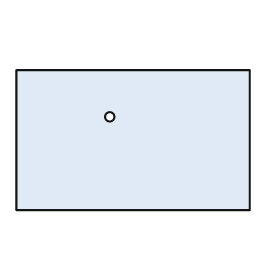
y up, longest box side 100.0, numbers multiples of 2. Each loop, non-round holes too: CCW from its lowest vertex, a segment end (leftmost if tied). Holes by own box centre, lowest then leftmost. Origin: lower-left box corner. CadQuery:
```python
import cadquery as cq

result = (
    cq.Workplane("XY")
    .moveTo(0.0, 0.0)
    .lineTo(100.0, 0.0)
    .lineTo(100.0, 60.0)
    .lineTo(0.0, 60.0)
    .close()
    .moveTo(40.0, 40.0)
    .circle(2.0)
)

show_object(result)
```